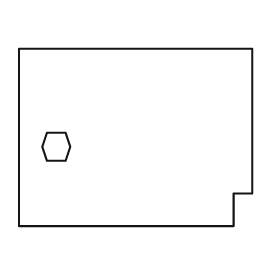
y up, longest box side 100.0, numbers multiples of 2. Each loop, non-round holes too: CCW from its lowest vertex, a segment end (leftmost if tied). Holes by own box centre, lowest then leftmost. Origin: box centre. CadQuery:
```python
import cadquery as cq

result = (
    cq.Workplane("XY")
    .moveTo(-50.0, -38.0)
    .lineTo(42.0, -38.0)
    .lineTo(42.0, -24.0)
    .lineTo(50.0, -24.0)
    .lineTo(50.0, 38.0)
    .lineTo(-50.0, 38.0)
    .close()
    .moveTo(-38.0, -10.0)
    .lineTo(-30.0, -10.0)
    .lineTo(-28.0, -4.0)
    .lineTo(-30.0, 2.0)
    .lineTo(-38.0, 2.0)
    .lineTo(-40.0, -4.0)
    .close()
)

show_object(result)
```